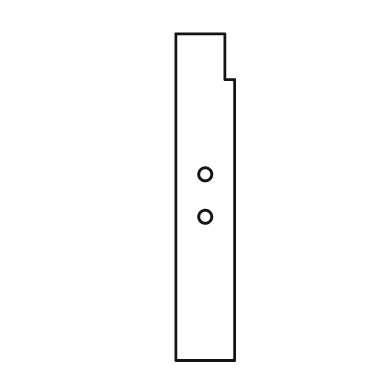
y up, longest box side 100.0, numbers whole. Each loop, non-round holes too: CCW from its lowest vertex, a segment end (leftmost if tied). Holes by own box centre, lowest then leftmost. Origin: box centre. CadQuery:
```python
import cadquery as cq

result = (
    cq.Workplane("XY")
    .moveTo(-9.0, -50.0)
    .lineTo(9.0, -50.0)
    .lineTo(9.0, 36.0)
    .lineTo(6.0, 36.0)
    .lineTo(6.0, 50.0)
    .lineTo(-9.0, 50.0)
    .close()
    .moveTo(0.0, -6.0)
    .circle(2.0)
    .moveTo(0.0, 7.0)
    .circle(2.0)
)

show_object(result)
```